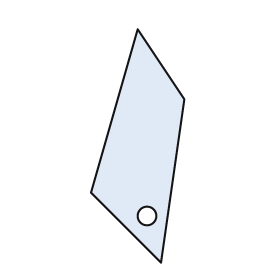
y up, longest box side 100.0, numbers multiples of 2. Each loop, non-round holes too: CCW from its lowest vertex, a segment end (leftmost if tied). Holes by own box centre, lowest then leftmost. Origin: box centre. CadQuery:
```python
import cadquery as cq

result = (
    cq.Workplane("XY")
    .moveTo(10.0, -50.0)
    .lineTo(20.0, 20.0)
    .lineTo(0.0, 50.0)
    .lineTo(-20.0, -20.0)
    .close()
    .moveTo(4.0, -30.0)
    .circle(4.0)
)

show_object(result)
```